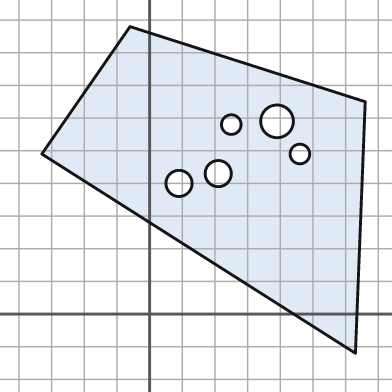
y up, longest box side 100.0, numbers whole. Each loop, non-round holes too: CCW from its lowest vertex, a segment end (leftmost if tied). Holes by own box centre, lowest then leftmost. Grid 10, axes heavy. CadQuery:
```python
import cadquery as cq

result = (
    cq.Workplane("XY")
    .moveTo(63.0, -12.0)
    .lineTo(66.0, 65.0)
    .lineTo(-6.0, 88.0)
    .lineTo(-33.0, 49.0)
    .close()
    .moveTo(9.0, 40.0)
    .circle(4.0)
    .moveTo(21.0, 43.0)
    .circle(4.0)
    .moveTo(46.0, 49.0)
    .circle(3.0)
    .moveTo(25.0, 58.0)
    .circle(3.0)
    .moveTo(39.0, 59.0)
    .circle(5.0)
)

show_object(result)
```